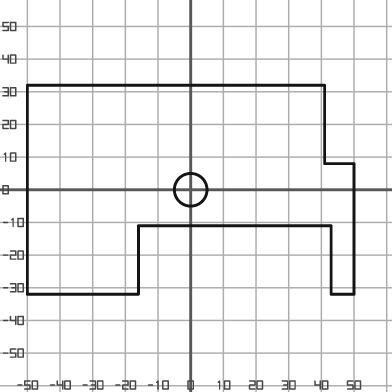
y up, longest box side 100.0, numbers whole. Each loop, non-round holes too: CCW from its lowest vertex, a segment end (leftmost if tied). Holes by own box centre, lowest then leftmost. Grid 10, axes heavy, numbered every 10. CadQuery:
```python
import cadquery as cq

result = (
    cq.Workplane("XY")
    .moveTo(-50.0, -32.0)
    .lineTo(-16.0, -32.0)
    .lineTo(-16.0, -11.0)
    .lineTo(43.0, -11.0)
    .lineTo(43.0, -32.0)
    .lineTo(50.0, -32.0)
    .lineTo(50.0, 8.0)
    .lineTo(41.0, 8.0)
    .lineTo(41.0, 32.0)
    .lineTo(-50.0, 32.0)
    .close()
    .moveTo(0.0, 0.0)
    .circle(5.0)
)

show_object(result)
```